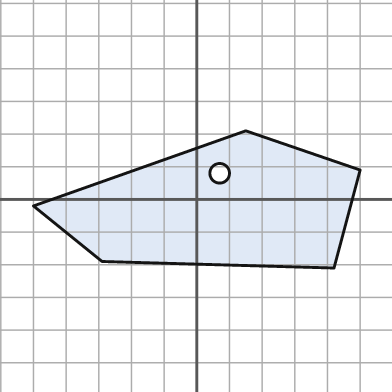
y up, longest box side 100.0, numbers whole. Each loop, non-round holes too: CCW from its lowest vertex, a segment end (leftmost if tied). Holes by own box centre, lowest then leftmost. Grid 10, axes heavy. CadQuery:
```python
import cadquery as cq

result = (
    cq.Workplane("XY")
    .moveTo(42.0, -21.0)
    .lineTo(50.0, 9.0)
    .lineTo(15.0, 21.0)
    .lineTo(-50.0, -2.0)
    .lineTo(-29.0, -19.0)
    .close()
    .moveTo(7.0, 8.0)
    .circle(3.0)
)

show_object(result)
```